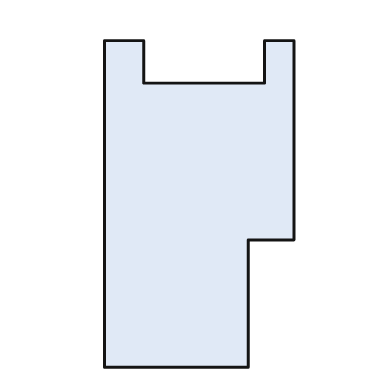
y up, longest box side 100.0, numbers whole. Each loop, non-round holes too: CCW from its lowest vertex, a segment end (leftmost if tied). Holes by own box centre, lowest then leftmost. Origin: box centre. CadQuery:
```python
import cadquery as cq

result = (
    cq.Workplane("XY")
    .moveTo(-29.0, -50.0)
    .lineTo(15.0, -50.0)
    .lineTo(15.0, -11.0)
    .lineTo(29.0, -11.0)
    .lineTo(29.0, 50.0)
    .lineTo(20.0, 50.0)
    .lineTo(20.0, 37.0)
    .lineTo(-17.0, 37.0)
    .lineTo(-17.0, 50.0)
    .lineTo(-29.0, 50.0)
    .close()
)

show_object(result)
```